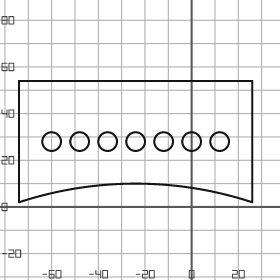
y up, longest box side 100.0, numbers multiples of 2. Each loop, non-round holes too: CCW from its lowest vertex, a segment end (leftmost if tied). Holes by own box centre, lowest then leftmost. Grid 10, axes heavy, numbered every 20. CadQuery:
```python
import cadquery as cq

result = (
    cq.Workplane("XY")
    .moveTo(-74.0, 2.0)
    .threePointArc((-24.0, 10.0), (26.0, 2.0))
    .lineTo(26.0, 54.0)
    .lineTo(-74.0, 54.0)
    .close()
    .moveTo(-60.0, 28.0)
    .circle(4.0)
    .moveTo(-48.0, 28.0)
    .circle(4.0)
    .moveTo(-36.0, 28.0)
    .circle(4.0)
    .moveTo(-24.0, 28.0)
    .circle(4.0)
    .moveTo(-12.0, 28.0)
    .circle(4.0)
    .moveTo(0.0, 28.0)
    .circle(4.0)
    .moveTo(12.0, 28.0)
    .circle(4.0)
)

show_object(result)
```